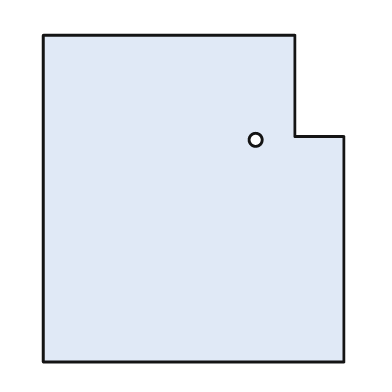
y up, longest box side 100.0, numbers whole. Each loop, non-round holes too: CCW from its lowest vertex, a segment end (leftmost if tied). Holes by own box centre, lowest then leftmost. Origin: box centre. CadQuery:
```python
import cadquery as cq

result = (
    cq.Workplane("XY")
    .moveTo(-46.0, -50.0)
    .lineTo(46.0, -50.0)
    .lineTo(46.0, 19.0)
    .lineTo(31.0, 19.0)
    .lineTo(31.0, 50.0)
    .lineTo(-46.0, 50.0)
    .close()
    .moveTo(19.0, 18.0)
    .circle(2.0)
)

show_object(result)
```